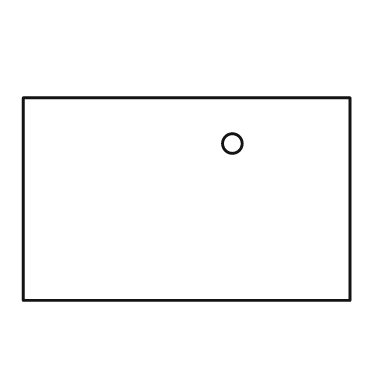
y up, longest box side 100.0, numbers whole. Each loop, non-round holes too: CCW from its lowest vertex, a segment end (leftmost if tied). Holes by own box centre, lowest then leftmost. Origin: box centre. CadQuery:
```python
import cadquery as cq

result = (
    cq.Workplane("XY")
    .moveTo(-50.0, -31.0)
    .lineTo(50.0, -31.0)
    .lineTo(50.0, 31.0)
    .lineTo(-50.0, 31.0)
    .close()
    .moveTo(14.0, 17.0)
    .circle(3.0)
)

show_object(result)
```